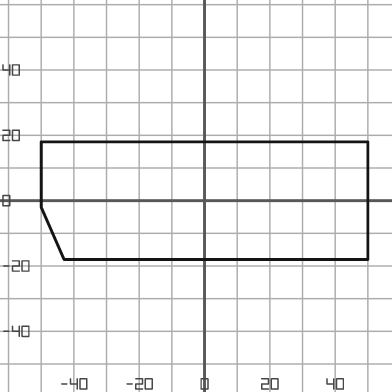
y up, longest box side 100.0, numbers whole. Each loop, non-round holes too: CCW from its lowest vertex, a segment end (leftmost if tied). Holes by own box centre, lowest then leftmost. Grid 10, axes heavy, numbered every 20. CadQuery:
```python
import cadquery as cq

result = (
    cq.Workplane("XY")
    .moveTo(-43.0, -18.0)
    .lineTo(50.0, -18.0)
    .lineTo(50.0, 18.0)
    .lineTo(-50.0, 18.0)
    .lineTo(-50.0, -2.0)
    .close()
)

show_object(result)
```